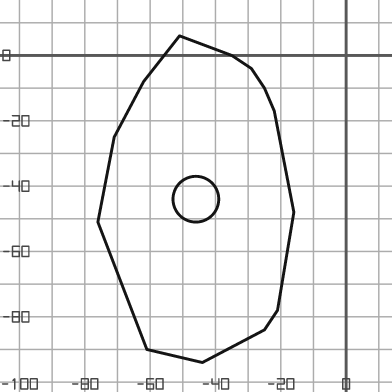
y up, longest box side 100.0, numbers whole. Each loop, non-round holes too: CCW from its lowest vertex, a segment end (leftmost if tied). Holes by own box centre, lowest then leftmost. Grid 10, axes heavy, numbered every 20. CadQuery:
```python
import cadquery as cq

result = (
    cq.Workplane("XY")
    .moveTo(-44.0, -94.0)
    .lineTo(-25.0, -84.0)
    .lineTo(-21.0, -78.0)
    .lineTo(-16.0, -48.0)
    .lineTo(-22.0, -17.0)
    .lineTo(-25.0, -10.0)
    .lineTo(-29.0, -4.0)
    .lineTo(-35.0, 0.0)
    .lineTo(-51.0, 6.0)
    .lineTo(-62.0, -8.0)
    .lineTo(-71.0, -25.0)
    .lineTo(-76.0, -51.0)
    .lineTo(-61.0, -90.0)
    .close()
    .moveTo(-46.0, -44.0)
    .circle(7.0)
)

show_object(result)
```